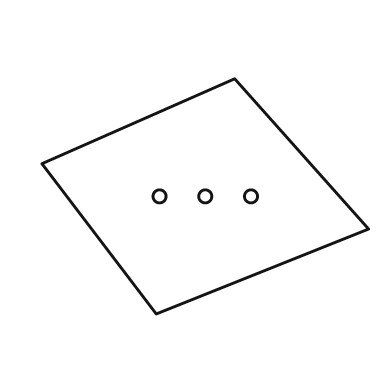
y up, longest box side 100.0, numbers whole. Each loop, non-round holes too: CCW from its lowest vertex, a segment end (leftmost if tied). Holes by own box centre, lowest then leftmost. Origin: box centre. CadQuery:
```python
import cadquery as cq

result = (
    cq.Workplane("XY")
    .moveTo(-15.0, -36.0)
    .lineTo(50.0, -10.0)
    .lineTo(9.0, 36.0)
    .lineTo(-50.0, 10.0)
    .close()
    .moveTo(-14.0, 0.0)
    .circle(2.0)
    .moveTo(0.0, 0.0)
    .circle(2.0)
    .moveTo(14.0, 0.0)
    .circle(2.0)
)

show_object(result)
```